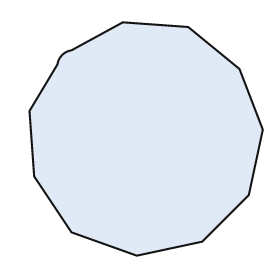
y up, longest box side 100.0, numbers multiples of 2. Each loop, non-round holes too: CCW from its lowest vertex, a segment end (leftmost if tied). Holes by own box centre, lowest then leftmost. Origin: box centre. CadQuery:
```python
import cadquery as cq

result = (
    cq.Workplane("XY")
    .moveTo(-4.0, -50.0)
    .lineTo(24.0, -44.0)
    .lineTo(44.0, -24.0)
    .lineTo(50.0, 4.0)
    .lineTo(40.0, 30.0)
    .lineTo(18.0, 48.0)
    .lineTo(-10.0, 50.0)
    .lineTo(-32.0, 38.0)
    .threePointArc((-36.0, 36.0), (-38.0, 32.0))
    .lineTo(-50.0, 12.0)
    .lineTo(-48.0, -16.0)
    .lineTo(-32.0, -40.0)
    .close()
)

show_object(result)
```